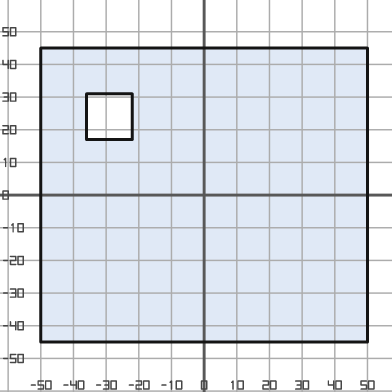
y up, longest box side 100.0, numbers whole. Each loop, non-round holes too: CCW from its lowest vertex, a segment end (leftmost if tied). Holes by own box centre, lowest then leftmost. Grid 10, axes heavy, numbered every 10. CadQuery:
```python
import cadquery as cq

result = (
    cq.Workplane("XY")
    .moveTo(-50.0, -45.0)
    .lineTo(50.0, -45.0)
    .lineTo(50.0, 45.0)
    .lineTo(-50.0, 45.0)
    .close()
    .moveTo(-36.0, 17.0)
    .lineTo(-22.0, 17.0)
    .lineTo(-22.0, 31.0)
    .lineTo(-36.0, 31.0)
    .close()
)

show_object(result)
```